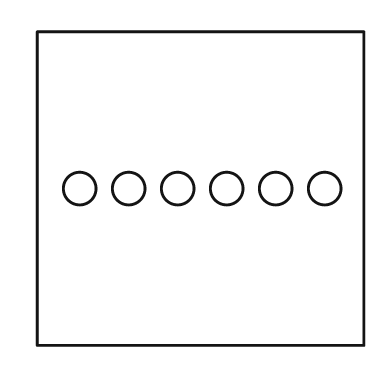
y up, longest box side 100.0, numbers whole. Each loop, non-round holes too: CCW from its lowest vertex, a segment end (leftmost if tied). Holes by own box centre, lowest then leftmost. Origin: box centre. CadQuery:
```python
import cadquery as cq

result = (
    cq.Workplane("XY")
    .moveTo(-50.0, -48.0)
    .lineTo(50.0, -48.0)
    .lineTo(50.0, 48.0)
    .lineTo(-50.0, 48.0)
    .close()
    .moveTo(-37.0, 0.0)
    .circle(5.0)
    .moveTo(-22.0, 0.0)
    .circle(5.0)
    .moveTo(-7.0, 0.0)
    .circle(5.0)
    .moveTo(8.0, 0.0)
    .circle(5.0)
    .moveTo(23.0, 0.0)
    .circle(5.0)
    .moveTo(38.0, 0.0)
    .circle(5.0)
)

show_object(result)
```